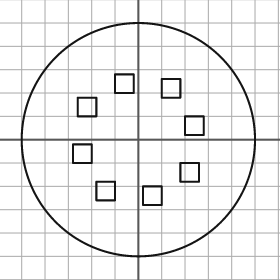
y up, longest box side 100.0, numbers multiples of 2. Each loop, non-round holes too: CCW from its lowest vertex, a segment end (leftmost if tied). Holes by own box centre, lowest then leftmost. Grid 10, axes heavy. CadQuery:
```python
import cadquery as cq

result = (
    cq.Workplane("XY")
    .moveTo(0.0, 0.0)
    .circle(50.0)
    .moveTo(2.0, -28.0)
    .lineTo(10.0, -28.0)
    .lineTo(10.0, -20.0)
    .lineTo(2.0, -20.0)
    .close()
    .moveTo(-18.0, -26.0)
    .lineTo(-10.0, -26.0)
    .lineTo(-10.0, -18.0)
    .lineTo(-18.0, -18.0)
    .close()
    .moveTo(18.0, -18.0)
    .lineTo(26.0, -18.0)
    .lineTo(26.0, -10.0)
    .lineTo(18.0, -10.0)
    .close()
    .moveTo(-28.0, -10.0)
    .lineTo(-20.0, -10.0)
    .lineTo(-20.0, -2.0)
    .lineTo(-28.0, -2.0)
    .close()
    .moveTo(20.0, 2.0)
    .lineTo(28.0, 2.0)
    .lineTo(28.0, 10.0)
    .lineTo(20.0, 10.0)
    .close()
    .moveTo(-26.0, 10.0)
    .lineTo(-18.0, 10.0)
    .lineTo(-18.0, 18.0)
    .lineTo(-26.0, 18.0)
    .close()
    .moveTo(10.0, 18.0)
    .lineTo(18.0, 18.0)
    .lineTo(18.0, 26.0)
    .lineTo(10.0, 26.0)
    .close()
    .moveTo(-10.0, 20.0)
    .lineTo(-2.0, 20.0)
    .lineTo(-2.0, 28.0)
    .lineTo(-10.0, 28.0)
    .close()
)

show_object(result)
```